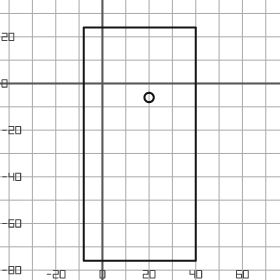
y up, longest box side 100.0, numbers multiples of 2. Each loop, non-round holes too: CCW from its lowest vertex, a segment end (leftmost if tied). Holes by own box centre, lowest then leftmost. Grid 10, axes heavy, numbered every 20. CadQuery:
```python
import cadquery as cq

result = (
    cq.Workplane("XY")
    .moveTo(-8.0, -76.0)
    .lineTo(40.0, -76.0)
    .lineTo(40.0, 24.0)
    .lineTo(-8.0, 24.0)
    .close()
    .moveTo(20.0, -6.0)
    .circle(2.0)
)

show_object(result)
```